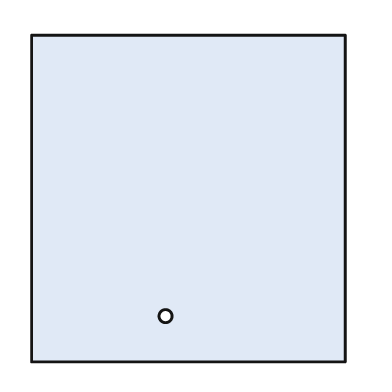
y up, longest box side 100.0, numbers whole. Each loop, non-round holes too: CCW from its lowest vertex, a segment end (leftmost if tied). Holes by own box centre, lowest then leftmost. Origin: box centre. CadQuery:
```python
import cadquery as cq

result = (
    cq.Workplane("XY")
    .moveTo(-48.0, -50.0)
    .lineTo(48.0, -50.0)
    .lineTo(48.0, 50.0)
    .lineTo(-48.0, 50.0)
    .close()
    .moveTo(-7.0, -36.0)
    .circle(2.0)
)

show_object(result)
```